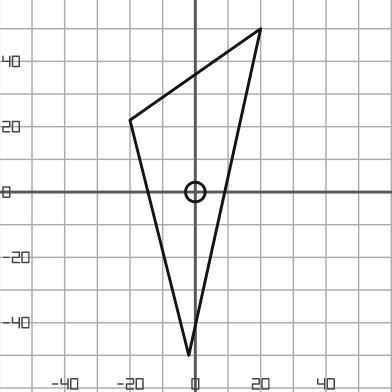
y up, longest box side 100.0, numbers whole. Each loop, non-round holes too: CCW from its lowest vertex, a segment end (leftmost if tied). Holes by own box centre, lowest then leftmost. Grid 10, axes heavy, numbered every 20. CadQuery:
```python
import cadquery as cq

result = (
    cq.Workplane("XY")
    .moveTo(-2.0, -50.0)
    .lineTo(20.0, 50.0)
    .lineTo(-20.0, 22.0)
    .close()
    .moveTo(0.0, 0.0)
    .circle(3.0)
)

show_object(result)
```